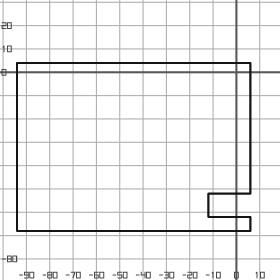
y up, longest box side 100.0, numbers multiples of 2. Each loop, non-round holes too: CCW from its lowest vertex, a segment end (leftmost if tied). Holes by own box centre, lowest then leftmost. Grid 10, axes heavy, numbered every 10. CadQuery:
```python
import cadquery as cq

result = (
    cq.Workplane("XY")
    .moveTo(-94.0, -68.0)
    .lineTo(6.0, -68.0)
    .lineTo(6.0, -62.0)
    .lineTo(-12.0, -62.0)
    .lineTo(-12.0, -52.0)
    .lineTo(6.0, -52.0)
    .lineTo(6.0, 4.0)
    .lineTo(-94.0, 4.0)
    .close()
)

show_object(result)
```